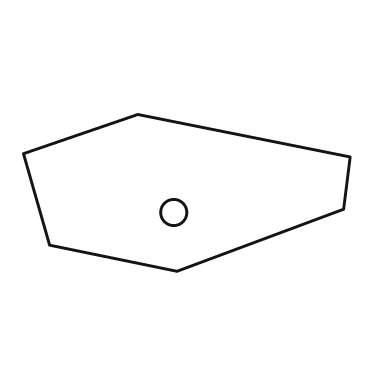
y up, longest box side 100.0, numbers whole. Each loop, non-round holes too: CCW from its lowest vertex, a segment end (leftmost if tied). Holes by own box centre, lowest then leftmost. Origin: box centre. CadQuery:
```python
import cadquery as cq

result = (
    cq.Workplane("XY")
    .moveTo(-3.0, -24.0)
    .lineTo(48.0, -5.0)
    .lineTo(50.0, 11.0)
    .lineTo(-15.0, 24.0)
    .lineTo(-50.0, 12.0)
    .lineTo(-42.0, -16.0)
    .close()
    .moveTo(-4.0, -6.0)
    .circle(4.0)
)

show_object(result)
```